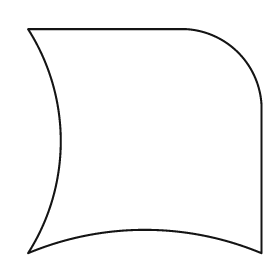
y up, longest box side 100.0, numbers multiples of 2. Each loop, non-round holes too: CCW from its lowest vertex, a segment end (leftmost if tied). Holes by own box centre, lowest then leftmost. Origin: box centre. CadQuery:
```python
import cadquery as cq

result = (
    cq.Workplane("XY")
    .moveTo(-50.0, -48.0)
    .threePointArc((0.0, -38.0), (50.0, -48.0))
    .lineTo(50.0, 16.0)
    .threePointArc((40.0, 38.0), (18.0, 48.0))
    .lineTo(-50.0, 48.0)
    .threePointArc((-36.0, 0.0), (-50.0, -48.0))
    .close()
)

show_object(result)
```